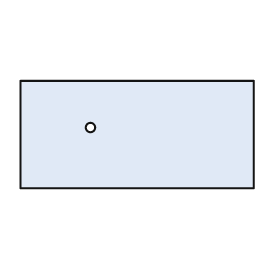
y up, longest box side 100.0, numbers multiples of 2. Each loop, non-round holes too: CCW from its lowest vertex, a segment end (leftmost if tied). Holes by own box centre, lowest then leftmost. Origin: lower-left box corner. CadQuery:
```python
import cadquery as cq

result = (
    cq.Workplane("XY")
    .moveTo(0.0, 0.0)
    .lineTo(100.0, 0.0)
    .lineTo(100.0, 46.0)
    .lineTo(0.0, 46.0)
    .close()
    .moveTo(30.0, 26.0)
    .circle(2.0)
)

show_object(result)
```